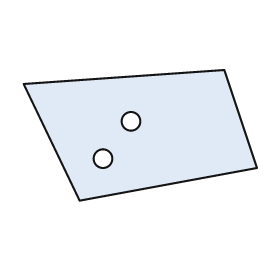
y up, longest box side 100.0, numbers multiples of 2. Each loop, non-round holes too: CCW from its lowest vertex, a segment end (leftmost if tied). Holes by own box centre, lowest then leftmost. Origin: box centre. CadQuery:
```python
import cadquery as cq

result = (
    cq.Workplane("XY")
    .moveTo(-26.0, -28.0)
    .lineTo(50.0, -14.0)
    .lineTo(36.0, 28.0)
    .lineTo(-50.0, 22.0)
    .close()
    .moveTo(-16.0, -10.0)
    .circle(4.0)
    .moveTo(-4.0, 6.0)
    .circle(4.0)
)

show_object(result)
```